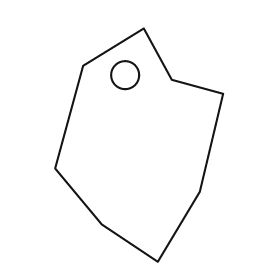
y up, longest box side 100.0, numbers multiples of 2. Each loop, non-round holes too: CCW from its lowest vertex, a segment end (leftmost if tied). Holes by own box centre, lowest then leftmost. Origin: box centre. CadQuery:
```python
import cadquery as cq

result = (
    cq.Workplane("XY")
    .moveTo(8.0, -50.0)
    .lineTo(26.0, -20.0)
    .lineTo(36.0, 22.0)
    .lineTo(14.0, 28.0)
    .lineTo(2.0, 50.0)
    .lineTo(-24.0, 34.0)
    .lineTo(-36.0, -10.0)
    .lineTo(-16.0, -34.0)
    .close()
    .moveTo(-6.0, 30.0)
    .circle(6.0)
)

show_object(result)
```